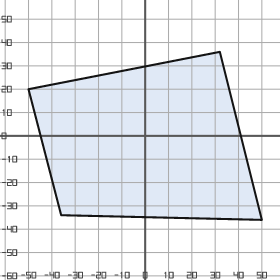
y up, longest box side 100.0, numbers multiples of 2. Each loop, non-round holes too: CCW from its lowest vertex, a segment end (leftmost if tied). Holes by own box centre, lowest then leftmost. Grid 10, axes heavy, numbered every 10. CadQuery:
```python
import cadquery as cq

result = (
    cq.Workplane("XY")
    .moveTo(50.0, -36.0)
    .lineTo(32.0, 36.0)
    .lineTo(-50.0, 20.0)
    .lineTo(-36.0, -34.0)
    .close()
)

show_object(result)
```